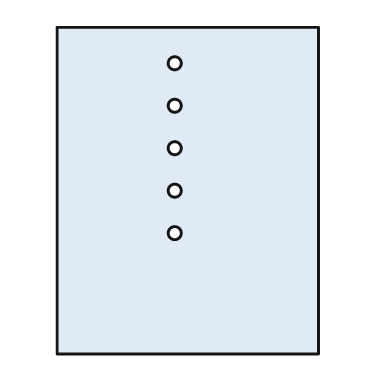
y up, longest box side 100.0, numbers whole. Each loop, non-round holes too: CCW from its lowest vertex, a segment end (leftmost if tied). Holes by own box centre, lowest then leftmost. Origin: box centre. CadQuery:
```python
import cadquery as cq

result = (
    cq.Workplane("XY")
    .moveTo(-40.0, -50.0)
    .lineTo(40.0, -50.0)
    .lineTo(40.0, 50.0)
    .lineTo(-40.0, 50.0)
    .close()
    .moveTo(-4.0, -13.0)
    .circle(2.0)
    .moveTo(-4.0, 0.0)
    .circle(2.0)
    .moveTo(-4.0, 13.0)
    .circle(2.0)
    .moveTo(-4.0, 26.0)
    .circle(2.0)
    .moveTo(-4.0, 39.0)
    .circle(2.0)
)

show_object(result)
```